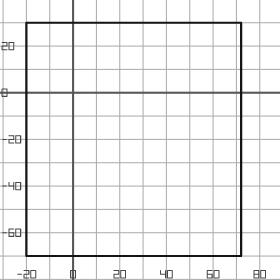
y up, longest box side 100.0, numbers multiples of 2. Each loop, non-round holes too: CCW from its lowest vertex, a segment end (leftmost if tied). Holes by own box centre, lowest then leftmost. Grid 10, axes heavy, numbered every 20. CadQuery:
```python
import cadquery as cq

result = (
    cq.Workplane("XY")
    .moveTo(-20.0, -70.0)
    .lineTo(72.0, -70.0)
    .lineTo(72.0, 30.0)
    .lineTo(-20.0, 30.0)
    .close()
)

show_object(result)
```